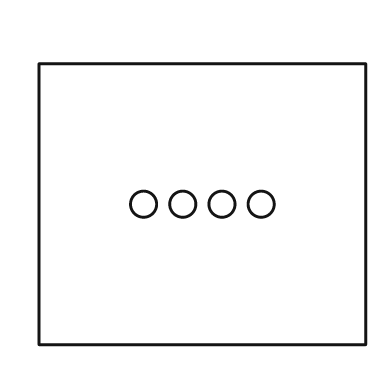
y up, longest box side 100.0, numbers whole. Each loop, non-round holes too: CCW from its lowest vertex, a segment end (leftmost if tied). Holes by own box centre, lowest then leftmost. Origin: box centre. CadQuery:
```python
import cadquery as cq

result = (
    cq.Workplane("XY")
    .moveTo(-50.0, -43.0)
    .lineTo(50.0, -43.0)
    .lineTo(50.0, 43.0)
    .lineTo(-50.0, 43.0)
    .close()
    .moveTo(-18.0, 0.0)
    .circle(4.0)
    .moveTo(-6.0, 0.0)
    .circle(4.0)
    .moveTo(6.0, 0.0)
    .circle(4.0)
    .moveTo(18.0, 0.0)
    .circle(4.0)
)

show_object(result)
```